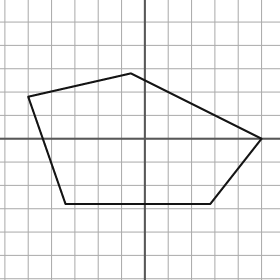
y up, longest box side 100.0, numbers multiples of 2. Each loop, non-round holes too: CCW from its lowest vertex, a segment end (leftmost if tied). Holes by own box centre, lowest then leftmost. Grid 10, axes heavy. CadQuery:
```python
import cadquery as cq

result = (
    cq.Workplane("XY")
    .moveTo(-34.0, -28.0)
    .lineTo(28.0, -28.0)
    .lineTo(50.0, 0.0)
    .lineTo(-6.0, 28.0)
    .lineTo(-50.0, 18.0)
    .close()
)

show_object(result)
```